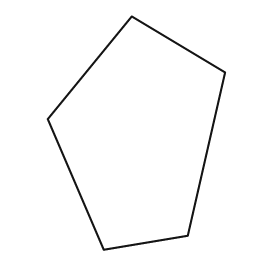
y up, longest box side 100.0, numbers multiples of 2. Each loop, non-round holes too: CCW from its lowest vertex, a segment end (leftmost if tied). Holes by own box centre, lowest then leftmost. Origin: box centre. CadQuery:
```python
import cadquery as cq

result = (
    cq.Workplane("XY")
    .moveTo(-14.0, -50.0)
    .lineTo(22.0, -44.0)
    .lineTo(38.0, 26.0)
    .lineTo(-2.0, 50.0)
    .lineTo(-38.0, 6.0)
    .close()
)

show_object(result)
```